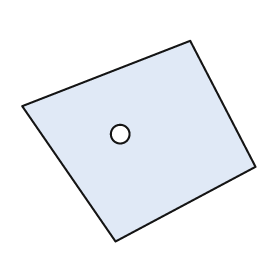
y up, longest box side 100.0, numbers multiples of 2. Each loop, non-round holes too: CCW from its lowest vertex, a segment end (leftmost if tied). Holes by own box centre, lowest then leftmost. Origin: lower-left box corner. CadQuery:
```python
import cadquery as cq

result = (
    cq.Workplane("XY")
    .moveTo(40.0, 0.0)
    .lineTo(100.0, 32.0)
    .lineTo(72.0, 86.0)
    .lineTo(0.0, 58.0)
    .close()
    .moveTo(42.0, 46.0)
    .circle(4.0)
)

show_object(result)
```